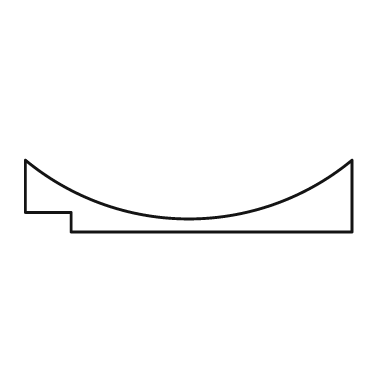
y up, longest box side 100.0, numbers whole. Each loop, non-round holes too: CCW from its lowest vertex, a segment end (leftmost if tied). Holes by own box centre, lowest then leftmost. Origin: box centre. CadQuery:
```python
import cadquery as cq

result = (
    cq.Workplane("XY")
    .moveTo(-36.0, -11.0)
    .lineTo(50.0, -11.0)
    .lineTo(50.0, 11.0)
    .threePointArc((0.0, -7.0), (-50.0, 11.0))
    .lineTo(-50.0, -5.0)
    .lineTo(-36.0, -5.0)
    .close()
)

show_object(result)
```